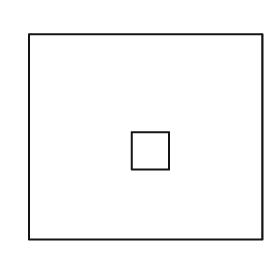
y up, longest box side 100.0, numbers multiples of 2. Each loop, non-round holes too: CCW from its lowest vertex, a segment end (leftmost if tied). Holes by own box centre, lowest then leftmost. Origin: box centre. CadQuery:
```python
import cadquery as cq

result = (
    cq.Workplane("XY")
    .moveTo(-50.0, -44.0)
    .lineTo(50.0, -44.0)
    .lineTo(50.0, 44.0)
    .lineTo(-50.0, 44.0)
    .close()
    .moveTo(-6.0, -14.0)
    .lineTo(10.0, -14.0)
    .lineTo(10.0, 2.0)
    .lineTo(-6.0, 2.0)
    .close()
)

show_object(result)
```